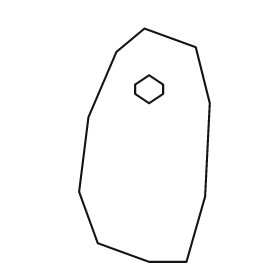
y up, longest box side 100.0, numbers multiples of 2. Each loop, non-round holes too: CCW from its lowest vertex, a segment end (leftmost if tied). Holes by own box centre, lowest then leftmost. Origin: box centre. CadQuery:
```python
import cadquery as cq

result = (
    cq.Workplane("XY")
    .moveTo(2.0, -50.0)
    .lineTo(18.0, -50.0)
    .lineTo(26.0, -22.0)
    .lineTo(28.0, 18.0)
    .lineTo(22.0, 42.0)
    .lineTo(0.0, 50.0)
    .lineTo(-12.0, 40.0)
    .lineTo(-24.0, 12.0)
    .lineTo(-28.0, -20.0)
    .lineTo(-20.0, -42.0)
    .close()
    .moveTo(2.0, 18.0)
    .lineTo(8.0, 22.0)
    .lineTo(8.0, 26.0)
    .lineTo(2.0, 30.0)
    .lineTo(-4.0, 26.0)
    .lineTo(-4.0, 22.0)
    .close()
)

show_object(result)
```